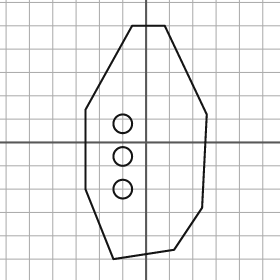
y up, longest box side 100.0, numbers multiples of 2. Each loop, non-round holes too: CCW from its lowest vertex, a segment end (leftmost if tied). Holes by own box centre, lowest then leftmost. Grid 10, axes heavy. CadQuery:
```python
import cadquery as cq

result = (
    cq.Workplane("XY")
    .moveTo(-14.0, -50.0)
    .lineTo(12.0, -46.0)
    .lineTo(24.0, -28.0)
    .lineTo(26.0, 12.0)
    .lineTo(8.0, 50.0)
    .lineTo(-6.0, 50.0)
    .lineTo(-26.0, 14.0)
    .lineTo(-26.0, -20.0)
    .close()
    .moveTo(-10.0, -20.0)
    .circle(4.0)
    .moveTo(-10.0, -6.0)
    .circle(4.0)
    .moveTo(-10.0, 8.0)
    .circle(4.0)
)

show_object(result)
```